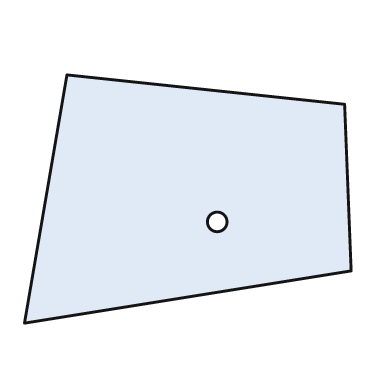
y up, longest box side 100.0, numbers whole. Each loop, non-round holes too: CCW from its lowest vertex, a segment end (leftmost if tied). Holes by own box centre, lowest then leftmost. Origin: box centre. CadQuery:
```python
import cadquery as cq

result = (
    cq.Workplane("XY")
    .moveTo(-50.0, -38.0)
    .lineTo(50.0, -22.0)
    .lineTo(48.0, 29.0)
    .lineTo(-37.0, 38.0)
    .close()
    .moveTo(9.0, -7.0)
    .circle(3.0)
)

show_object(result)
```